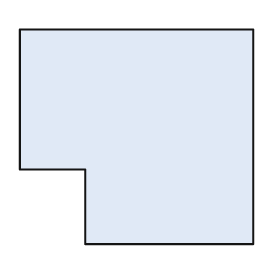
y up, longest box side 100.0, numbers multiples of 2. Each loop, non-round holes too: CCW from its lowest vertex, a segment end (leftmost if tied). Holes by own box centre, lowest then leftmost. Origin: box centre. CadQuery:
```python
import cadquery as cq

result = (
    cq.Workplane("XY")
    .moveTo(-22.0, -46.0)
    .lineTo(50.0, -46.0)
    .lineTo(50.0, 46.0)
    .lineTo(-50.0, 46.0)
    .lineTo(-50.0, -14.0)
    .lineTo(-22.0, -14.0)
    .close()
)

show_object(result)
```